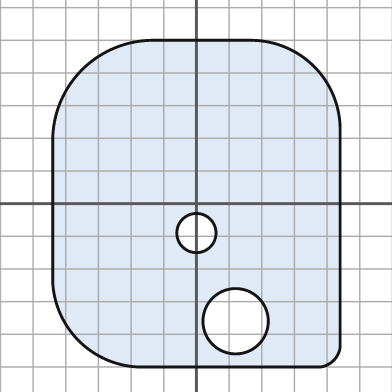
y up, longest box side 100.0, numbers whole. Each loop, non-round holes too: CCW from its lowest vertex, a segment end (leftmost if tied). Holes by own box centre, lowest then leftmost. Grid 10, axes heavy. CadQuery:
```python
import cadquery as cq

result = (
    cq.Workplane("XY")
    .moveTo(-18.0, -50.0)
    .lineTo(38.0, -50.0)
    .threePointArc((42.0, -48.0), (44.0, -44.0))
    .lineTo(44.0, 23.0)
    .threePointArc((36.0, 42.0), (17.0, 50.0))
    .lineTo(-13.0, 50.0)
    .threePointArc((-35.0, 41.0), (-44.0, 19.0))
    .lineTo(-44.0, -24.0)
    .threePointArc((-36.0, -42.0), (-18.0, -50.0))
    .close()
    .moveTo(12.0, -36.0)
    .circle(10.0)
    .moveTo(0.0, -9.0)
    .circle(6.0)
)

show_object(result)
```